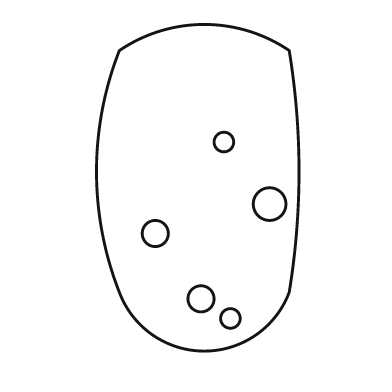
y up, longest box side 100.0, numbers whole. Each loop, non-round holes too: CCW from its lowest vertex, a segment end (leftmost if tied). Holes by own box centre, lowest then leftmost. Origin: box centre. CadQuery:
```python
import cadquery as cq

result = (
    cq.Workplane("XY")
    .moveTo(-24.0, -32.0)
    .threePointArc((2.0, -50.0), (28.0, -32.0))
    .threePointArc((31.0, 5.0), (28.0, 42.0))
    .threePointArc((2.0, 50.0), (-24.0, 42.0))
    .threePointArc((-31.0, 5.0), (-24.0, -32.0))
    .close()
    .moveTo(10.0, -40.0)
    .circle(3.0)
    .moveTo(1.0, -34.0)
    .circle(4.0)
    .moveTo(-13.0, -14.0)
    .circle(4.0)
    .moveTo(22.0, -5.0)
    .circle(5.0)
    .moveTo(8.0, 14.0)
    .circle(3.0)
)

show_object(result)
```